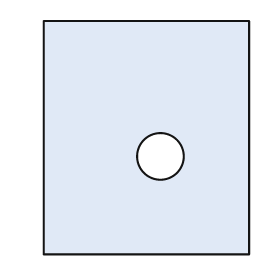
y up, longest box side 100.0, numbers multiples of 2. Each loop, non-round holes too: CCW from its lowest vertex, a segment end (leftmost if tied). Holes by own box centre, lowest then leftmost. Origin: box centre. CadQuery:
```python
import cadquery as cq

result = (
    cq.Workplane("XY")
    .moveTo(-44.0, -50.0)
    .lineTo(44.0, -50.0)
    .lineTo(44.0, 50.0)
    .lineTo(-44.0, 50.0)
    .close()
    .moveTo(6.0, -8.0)
    .circle(10.0)
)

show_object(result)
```